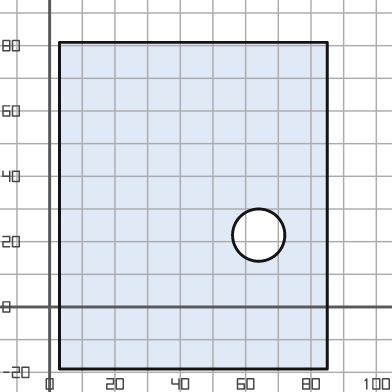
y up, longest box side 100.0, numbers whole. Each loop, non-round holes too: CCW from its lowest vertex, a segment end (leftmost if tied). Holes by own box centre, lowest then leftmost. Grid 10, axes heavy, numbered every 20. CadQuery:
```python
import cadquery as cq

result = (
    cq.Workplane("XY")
    .moveTo(3.0, -19.0)
    .lineTo(85.0, -19.0)
    .lineTo(85.0, 81.0)
    .lineTo(3.0, 81.0)
    .close()
    .moveTo(64.0, 22.0)
    .circle(8.0)
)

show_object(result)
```